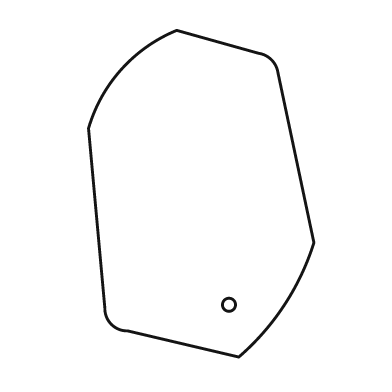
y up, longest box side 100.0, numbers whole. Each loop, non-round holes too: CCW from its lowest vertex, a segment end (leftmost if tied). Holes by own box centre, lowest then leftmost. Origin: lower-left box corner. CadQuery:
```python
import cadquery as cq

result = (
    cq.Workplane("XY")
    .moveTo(46.0, 0.0)
    .threePointArc((60.0, 16.0), (69.0, 35.0))
    .lineTo(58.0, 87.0)
    .threePointArc((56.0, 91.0), (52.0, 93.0))
    .lineTo(27.0, 100.0)
    .threePointArc((10.0, 88.0), (0.0, 70.0))
    .lineTo(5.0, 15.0)
    .threePointArc((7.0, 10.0), (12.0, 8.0))
    .close()
    .moveTo(43.0, 16.0)
    .circle(2.0)
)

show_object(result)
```